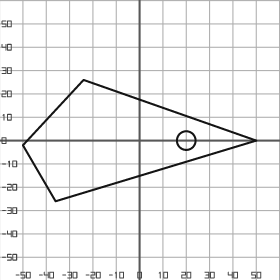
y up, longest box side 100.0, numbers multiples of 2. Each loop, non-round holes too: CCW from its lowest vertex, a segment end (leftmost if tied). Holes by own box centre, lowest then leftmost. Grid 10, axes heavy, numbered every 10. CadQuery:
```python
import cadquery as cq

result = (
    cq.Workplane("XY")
    .moveTo(-36.0, -26.0)
    .lineTo(50.0, 0.0)
    .lineTo(-24.0, 26.0)
    .lineTo(-50.0, -2.0)
    .close()
    .moveTo(20.0, 0.0)
    .circle(4.0)
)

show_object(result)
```